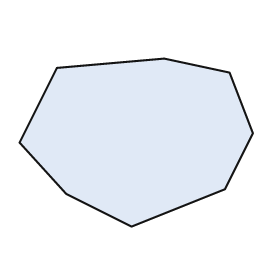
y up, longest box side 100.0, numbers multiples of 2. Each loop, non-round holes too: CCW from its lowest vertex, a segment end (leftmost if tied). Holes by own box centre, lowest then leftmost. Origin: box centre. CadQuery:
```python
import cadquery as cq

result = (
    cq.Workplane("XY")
    .moveTo(-2.0, -36.0)
    .lineTo(38.0, -20.0)
    .lineTo(50.0, 4.0)
    .lineTo(40.0, 30.0)
    .lineTo(12.0, 36.0)
    .lineTo(-34.0, 32.0)
    .lineTo(-50.0, 0.0)
    .lineTo(-30.0, -22.0)
    .close()
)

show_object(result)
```